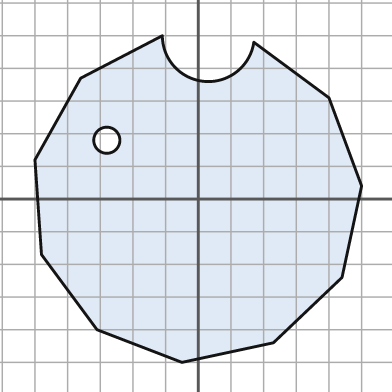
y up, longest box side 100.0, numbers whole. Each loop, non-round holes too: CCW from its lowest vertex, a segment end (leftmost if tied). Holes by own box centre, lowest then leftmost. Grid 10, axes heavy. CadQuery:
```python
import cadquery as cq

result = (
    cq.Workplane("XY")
    .moveTo(-5.0, -50.0)
    .lineTo(23.0, -44.0)
    .lineTo(44.0, -24.0)
    .lineTo(50.0, 4.0)
    .lineTo(40.0, 31.0)
    .lineTo(17.0, 48.0)
    .threePointArc((2.0, 36.0), (-11.0, 50.0))
    .lineTo(-36.0, 37.0)
    .lineTo(-50.0, 12.0)
    .lineTo(-48.0, -17.0)
    .lineTo(-31.0, -40.0)
    .close()
    .moveTo(-28.0, 18.0)
    .circle(4.0)
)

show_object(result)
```